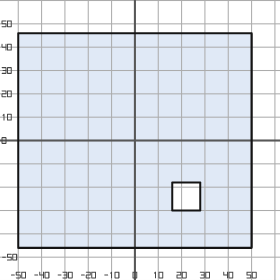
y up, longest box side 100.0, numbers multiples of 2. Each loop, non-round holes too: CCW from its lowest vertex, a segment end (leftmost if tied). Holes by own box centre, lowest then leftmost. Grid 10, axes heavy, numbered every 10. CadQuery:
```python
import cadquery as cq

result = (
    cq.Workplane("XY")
    .moveTo(-50.0, -46.0)
    .lineTo(50.0, -46.0)
    .lineTo(50.0, 46.0)
    .lineTo(-50.0, 46.0)
    .close()
    .moveTo(16.0, -30.0)
    .lineTo(28.0, -30.0)
    .lineTo(28.0, -18.0)
    .lineTo(16.0, -18.0)
    .close()
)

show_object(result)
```